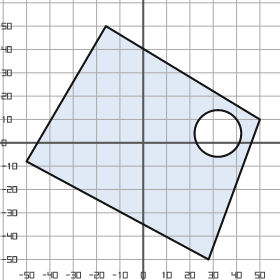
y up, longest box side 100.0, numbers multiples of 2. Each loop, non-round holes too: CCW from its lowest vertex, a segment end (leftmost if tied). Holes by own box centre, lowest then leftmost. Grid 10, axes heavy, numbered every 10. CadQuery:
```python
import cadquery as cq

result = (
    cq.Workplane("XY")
    .moveTo(28.0, -50.0)
    .lineTo(50.0, 10.0)
    .lineTo(-16.0, 50.0)
    .lineTo(-50.0, -8.0)
    .close()
    .moveTo(32.0, 4.0)
    .circle(10.0)
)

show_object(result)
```